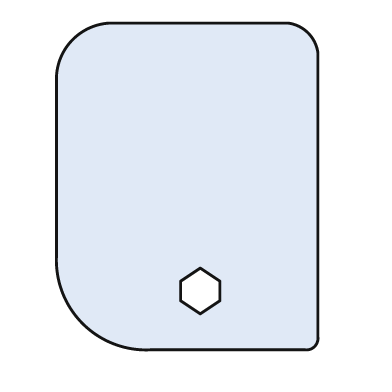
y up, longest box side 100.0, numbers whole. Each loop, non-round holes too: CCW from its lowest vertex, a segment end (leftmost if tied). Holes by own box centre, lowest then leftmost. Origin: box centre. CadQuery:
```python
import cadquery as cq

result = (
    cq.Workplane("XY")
    .moveTo(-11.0, -50.0)
    .lineTo(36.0, -50.0)
    .threePointArc((39.0, -49.0), (40.0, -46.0))
    .lineTo(40.0, 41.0)
    .threePointArc((37.0, 47.0), (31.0, 50.0))
    .lineTo(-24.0, 50.0)
    .threePointArc((-35.0, 45.0), (-40.0, 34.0))
    .lineTo(-40.0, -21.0)
    .threePointArc((-32.0, -42.0), (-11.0, -50.0))
    .close()
    .moveTo(4.0, -39.0)
    .lineTo(10.0, -35.0)
    .lineTo(10.0, -29.0)
    .lineTo(4.0, -25.0)
    .lineTo(-2.0, -29.0)
    .lineTo(-2.0, -35.0)
    .close()
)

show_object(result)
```